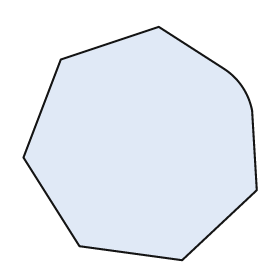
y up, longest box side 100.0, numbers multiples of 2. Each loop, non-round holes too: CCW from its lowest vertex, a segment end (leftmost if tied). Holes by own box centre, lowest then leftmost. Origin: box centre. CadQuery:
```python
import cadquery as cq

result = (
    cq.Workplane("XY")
    .moveTo(18.0, -50.0)
    .lineTo(50.0, -20.0)
    .lineTo(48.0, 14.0)
    .threePointArc((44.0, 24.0), (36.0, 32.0))
    .lineTo(8.0, 50.0)
    .lineTo(-34.0, 36.0)
    .lineTo(-50.0, -6.0)
    .lineTo(-26.0, -44.0)
    .close()
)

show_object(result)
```